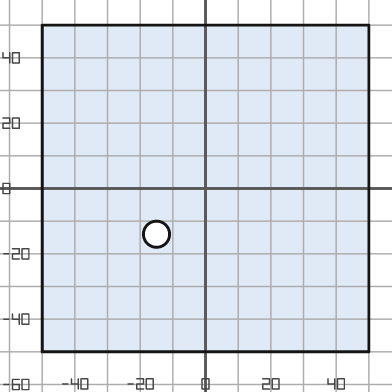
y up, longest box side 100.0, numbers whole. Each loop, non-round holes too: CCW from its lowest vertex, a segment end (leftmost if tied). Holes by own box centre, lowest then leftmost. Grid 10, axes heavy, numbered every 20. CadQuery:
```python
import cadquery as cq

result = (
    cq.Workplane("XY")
    .moveTo(-50.0, -50.0)
    .lineTo(50.0, -50.0)
    .lineTo(50.0, 50.0)
    .lineTo(-50.0, 50.0)
    .close()
    .moveTo(-15.0, -14.0)
    .circle(4.0)
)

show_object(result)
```